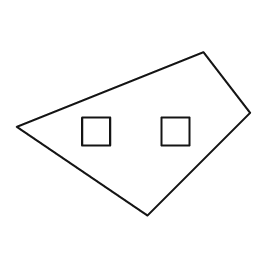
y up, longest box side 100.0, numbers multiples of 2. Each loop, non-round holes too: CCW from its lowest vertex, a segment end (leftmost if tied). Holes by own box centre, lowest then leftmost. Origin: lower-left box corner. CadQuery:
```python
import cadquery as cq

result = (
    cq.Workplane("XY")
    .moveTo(56.0, 0.0)
    .lineTo(100.0, 44.0)
    .lineTo(80.0, 70.0)
    .lineTo(0.0, 38.0)
    .close()
    .moveTo(28.0, 30.0)
    .lineTo(40.0, 30.0)
    .lineTo(40.0, 42.0)
    .lineTo(28.0, 42.0)
    .close()
    .moveTo(62.0, 30.0)
    .lineTo(74.0, 30.0)
    .lineTo(74.0, 42.0)
    .lineTo(62.0, 42.0)
    .close()
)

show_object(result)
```